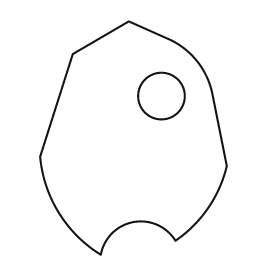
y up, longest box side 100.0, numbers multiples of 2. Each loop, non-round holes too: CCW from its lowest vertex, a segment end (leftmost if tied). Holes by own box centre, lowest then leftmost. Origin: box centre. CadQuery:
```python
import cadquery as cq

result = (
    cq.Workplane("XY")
    .moveTo(-14.0, -50.0)
    .threePointArc((0.0, -36.0), (18.0, -44.0))
    .threePointArc((32.0, -30.0), (40.0, -12.0))
    .lineTo(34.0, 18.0)
    .threePointArc((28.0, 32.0), (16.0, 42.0))
    .lineTo(-2.0, 50.0)
    .lineTo(-26.0, 36.0)
    .lineTo(-40.0, -8.0)
    .threePointArc((-32.0, -32.0), (-14.0, -50.0))
    .close()
    .moveTo(12.0, 18.0)
    .circle(10.0)
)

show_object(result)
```